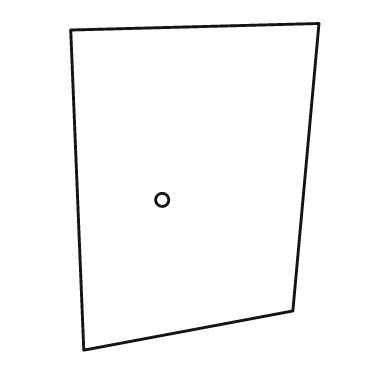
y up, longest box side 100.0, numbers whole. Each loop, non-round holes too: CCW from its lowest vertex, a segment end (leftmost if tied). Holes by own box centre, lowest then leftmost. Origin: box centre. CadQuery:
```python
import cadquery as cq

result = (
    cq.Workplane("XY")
    .moveTo(-34.0, -50.0)
    .lineTo(30.0, -38.0)
    .lineTo(38.0, 50.0)
    .lineTo(-38.0, 48.0)
    .close()
    .moveTo(-10.0, -4.0)
    .circle(2.0)
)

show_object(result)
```